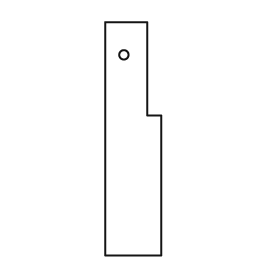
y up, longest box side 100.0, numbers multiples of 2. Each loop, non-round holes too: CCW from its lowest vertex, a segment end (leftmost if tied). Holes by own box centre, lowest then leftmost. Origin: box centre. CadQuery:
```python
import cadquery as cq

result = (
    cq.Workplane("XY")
    .moveTo(-12.0, -50.0)
    .lineTo(12.0, -50.0)
    .lineTo(12.0, 10.0)
    .lineTo(6.0, 10.0)
    .lineTo(6.0, 50.0)
    .lineTo(-12.0, 50.0)
    .close()
    .moveTo(-4.0, 36.0)
    .circle(2.0)
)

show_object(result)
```